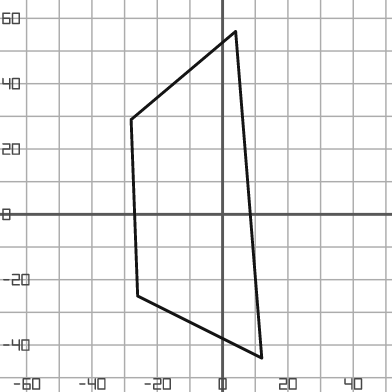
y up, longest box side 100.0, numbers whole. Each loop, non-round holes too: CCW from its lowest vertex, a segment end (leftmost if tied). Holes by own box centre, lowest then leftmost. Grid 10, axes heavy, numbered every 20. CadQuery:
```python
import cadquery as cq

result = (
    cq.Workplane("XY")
    .moveTo(12.0, -44.0)
    .lineTo(4.0, 56.0)
    .lineTo(-28.0, 29.0)
    .lineTo(-26.0, -25.0)
    .close()
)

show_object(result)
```